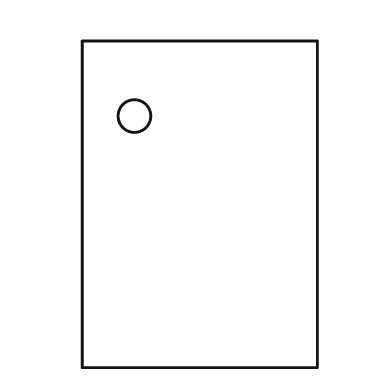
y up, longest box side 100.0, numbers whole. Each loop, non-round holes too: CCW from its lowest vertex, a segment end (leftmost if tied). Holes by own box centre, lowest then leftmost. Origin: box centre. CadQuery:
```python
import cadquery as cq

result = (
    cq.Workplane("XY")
    .moveTo(-36.0, -50.0)
    .lineTo(36.0, -50.0)
    .lineTo(36.0, 50.0)
    .lineTo(-36.0, 50.0)
    .close()
    .moveTo(-20.0, 27.0)
    .circle(5.0)
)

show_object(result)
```